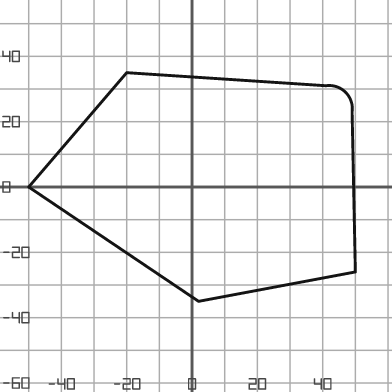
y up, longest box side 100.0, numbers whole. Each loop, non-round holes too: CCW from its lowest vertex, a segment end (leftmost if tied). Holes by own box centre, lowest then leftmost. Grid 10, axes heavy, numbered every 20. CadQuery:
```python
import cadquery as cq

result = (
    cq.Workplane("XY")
    .moveTo(2.0, -35.0)
    .lineTo(50.0, -26.0)
    .lineTo(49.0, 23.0)
    .threePointArc((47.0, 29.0), (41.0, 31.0))
    .lineTo(-20.0, 35.0)
    .lineTo(-50.0, 0.0)
    .close()
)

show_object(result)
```